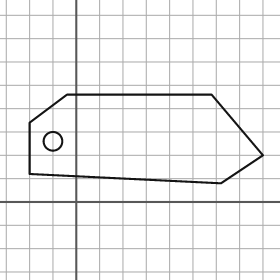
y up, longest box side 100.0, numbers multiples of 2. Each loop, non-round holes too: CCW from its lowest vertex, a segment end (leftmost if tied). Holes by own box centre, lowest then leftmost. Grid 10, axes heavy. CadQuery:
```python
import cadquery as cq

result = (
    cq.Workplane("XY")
    .moveTo(62.0, 8.0)
    .lineTo(80.0, 20.0)
    .lineTo(58.0, 46.0)
    .lineTo(-4.0, 46.0)
    .lineTo(-20.0, 34.0)
    .lineTo(-20.0, 12.0)
    .close()
    .moveTo(-10.0, 26.0)
    .circle(4.0)
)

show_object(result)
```